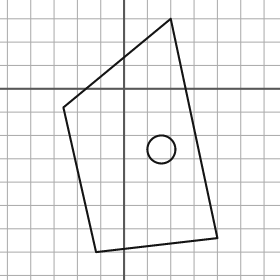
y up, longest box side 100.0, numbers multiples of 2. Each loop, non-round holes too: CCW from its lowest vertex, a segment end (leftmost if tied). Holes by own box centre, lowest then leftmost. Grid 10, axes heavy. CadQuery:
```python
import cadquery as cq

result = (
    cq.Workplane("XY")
    .moveTo(-12.0, -70.0)
    .lineTo(40.0, -64.0)
    .lineTo(20.0, 30.0)
    .lineTo(-26.0, -8.0)
    .close()
    .moveTo(16.0, -26.0)
    .circle(6.0)
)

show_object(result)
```